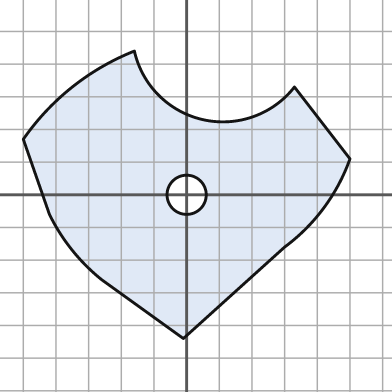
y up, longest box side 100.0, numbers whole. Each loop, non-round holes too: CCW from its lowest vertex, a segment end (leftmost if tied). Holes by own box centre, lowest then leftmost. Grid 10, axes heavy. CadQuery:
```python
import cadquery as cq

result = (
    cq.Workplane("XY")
    .moveTo(-1.0, -44.0)
    .lineTo(30.0, -16.0)
    .threePointArc((42.0, -4.0), (50.0, 11.0))
    .lineTo(33.0, 33.0)
    .threePointArc((5.0, 23.0), (-16.0, 44.0))
    .threePointArc((-35.0, 33.0), (-50.0, 17.0))
    .lineTo(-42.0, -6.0)
    .threePointArc((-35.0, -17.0), (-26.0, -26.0))
    .close()
    .moveTo(0.0, 0.0)
    .circle(6.0)
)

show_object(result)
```